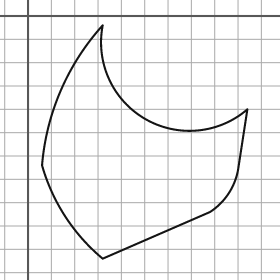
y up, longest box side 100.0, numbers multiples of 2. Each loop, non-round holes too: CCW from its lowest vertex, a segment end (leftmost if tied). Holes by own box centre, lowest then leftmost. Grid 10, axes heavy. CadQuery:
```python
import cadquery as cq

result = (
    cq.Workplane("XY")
    .moveTo(32.0, -104.0)
    .lineTo(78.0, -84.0)
    .threePointArc((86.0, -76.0), (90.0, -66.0))
    .lineTo(94.0, -40.0)
    .threePointArc((50.0, -44.0), (32.0, -4.0))
    .threePointArc((14.0, -32.0), (6.0, -64.0))
    .threePointArc((16.0, -86.0), (32.0, -104.0))
    .close()
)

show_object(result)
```